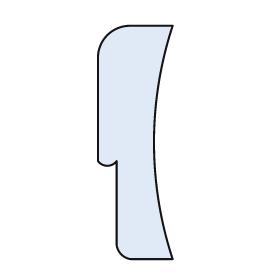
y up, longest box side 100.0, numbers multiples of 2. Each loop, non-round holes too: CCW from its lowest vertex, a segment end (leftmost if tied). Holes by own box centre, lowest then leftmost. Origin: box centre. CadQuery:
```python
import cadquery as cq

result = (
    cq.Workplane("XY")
    .moveTo(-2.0, -50.0)
    .lineTo(16.0, -50.0)
    .threePointArc((8.0, 0.0), (16.0, 50.0))
    .lineTo(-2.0, 50.0)
    .threePointArc((-12.0, 46.0), (-16.0, 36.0))
    .lineTo(-16.0, -8.0)
    .threePointArc((-12.0, -10.0), (-8.0, -8.0))
    .lineTo(-8.0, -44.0)
    .threePointArc((-6.0, -48.0), (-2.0, -50.0))
    .close()
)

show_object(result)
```